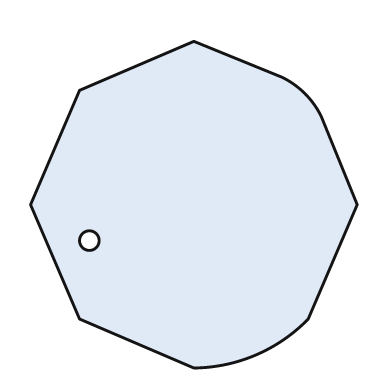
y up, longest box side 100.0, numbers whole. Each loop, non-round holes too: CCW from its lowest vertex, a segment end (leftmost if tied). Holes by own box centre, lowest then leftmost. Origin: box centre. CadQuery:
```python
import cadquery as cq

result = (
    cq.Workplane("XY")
    .moveTo(0.0, -50.0)
    .threePointArc((19.0, -46.0), (35.0, -35.0))
    .lineTo(50.0, 0.0)
    .lineTo(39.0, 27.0)
    .threePointArc((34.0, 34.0), (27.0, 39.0))
    .lineTo(0.0, 50.0)
    .lineTo(-35.0, 35.0)
    .lineTo(-50.0, 0.0)
    .lineTo(-35.0, -35.0)
    .close()
    .moveTo(-32.0, -11.0)
    .circle(3.0)
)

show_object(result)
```